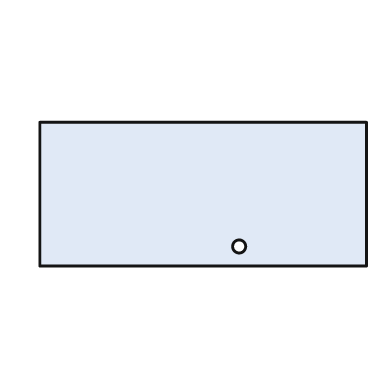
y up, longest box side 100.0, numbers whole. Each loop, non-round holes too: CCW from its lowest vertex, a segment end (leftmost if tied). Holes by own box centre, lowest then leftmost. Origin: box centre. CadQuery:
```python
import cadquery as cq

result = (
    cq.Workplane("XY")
    .moveTo(-50.0, -22.0)
    .lineTo(50.0, -22.0)
    .lineTo(50.0, 22.0)
    .lineTo(-50.0, 22.0)
    .close()
    .moveTo(11.0, -16.0)
    .circle(2.0)
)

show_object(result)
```